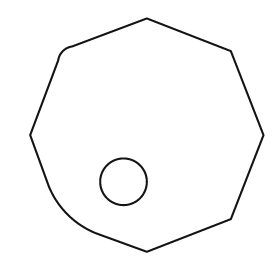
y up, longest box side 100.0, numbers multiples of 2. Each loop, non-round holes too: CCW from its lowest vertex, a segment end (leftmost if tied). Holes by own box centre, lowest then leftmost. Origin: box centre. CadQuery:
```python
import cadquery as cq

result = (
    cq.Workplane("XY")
    .moveTo(0.0, -50.0)
    .lineTo(36.0, -36.0)
    .lineTo(50.0, 0.0)
    .lineTo(36.0, 36.0)
    .lineTo(0.0, 50.0)
    .lineTo(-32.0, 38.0)
    .threePointArc((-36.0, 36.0), (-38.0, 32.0))
    .lineTo(-50.0, 0.0)
    .lineTo(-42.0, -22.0)
    .threePointArc((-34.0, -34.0), (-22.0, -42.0))
    .close()
    .moveTo(-10.0, -20.0)
    .circle(10.0)
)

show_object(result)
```